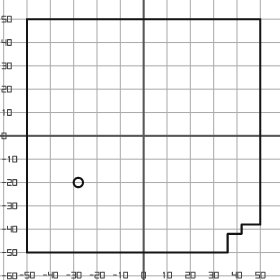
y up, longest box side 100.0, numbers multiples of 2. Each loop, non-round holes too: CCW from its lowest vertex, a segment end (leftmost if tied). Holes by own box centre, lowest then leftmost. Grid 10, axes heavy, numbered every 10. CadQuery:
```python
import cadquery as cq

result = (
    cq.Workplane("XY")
    .moveTo(-50.0, -50.0)
    .lineTo(36.0, -50.0)
    .lineTo(36.0, -42.0)
    .lineTo(42.0, -42.0)
    .lineTo(42.0, -38.0)
    .lineTo(50.0, -38.0)
    .lineTo(50.0, 50.0)
    .lineTo(-50.0, 50.0)
    .close()
    .moveTo(-28.0, -20.0)
    .circle(2.0)
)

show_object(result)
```